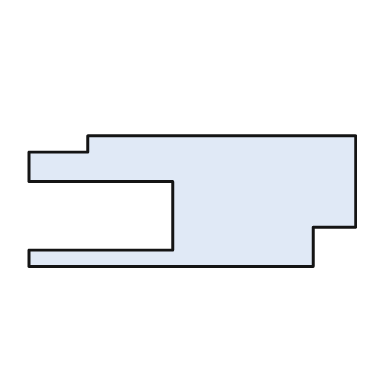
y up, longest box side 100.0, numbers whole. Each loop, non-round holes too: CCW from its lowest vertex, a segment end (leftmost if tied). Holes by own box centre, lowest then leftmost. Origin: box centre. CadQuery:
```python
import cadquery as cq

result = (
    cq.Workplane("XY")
    .moveTo(-50.0, -20.0)
    .lineTo(37.0, -20.0)
    .lineTo(37.0, -8.0)
    .lineTo(50.0, -8.0)
    .lineTo(50.0, 20.0)
    .lineTo(-32.0, 20.0)
    .lineTo(-32.0, 15.0)
    .lineTo(-50.0, 15.0)
    .lineTo(-50.0, 6.0)
    .lineTo(-6.0, 6.0)
    .lineTo(-6.0, -15.0)
    .lineTo(-50.0, -15.0)
    .close()
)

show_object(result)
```